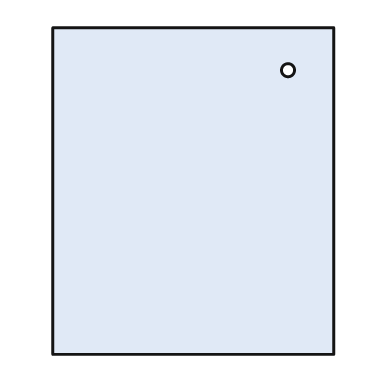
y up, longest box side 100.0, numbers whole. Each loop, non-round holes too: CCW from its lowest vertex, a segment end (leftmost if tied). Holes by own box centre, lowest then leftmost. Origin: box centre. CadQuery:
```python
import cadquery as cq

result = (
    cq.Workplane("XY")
    .moveTo(-43.0, -50.0)
    .lineTo(43.0, -50.0)
    .lineTo(43.0, 50.0)
    .lineTo(-43.0, 50.0)
    .close()
    .moveTo(29.0, 37.0)
    .circle(2.0)
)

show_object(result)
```